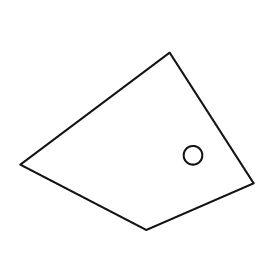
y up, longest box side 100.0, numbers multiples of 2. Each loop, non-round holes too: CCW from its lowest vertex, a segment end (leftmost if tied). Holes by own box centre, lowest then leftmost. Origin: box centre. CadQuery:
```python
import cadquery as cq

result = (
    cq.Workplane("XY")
    .moveTo(4.0, -38.0)
    .lineTo(50.0, -18.0)
    .lineTo(14.0, 38.0)
    .lineTo(-50.0, -10.0)
    .close()
    .moveTo(24.0, -6.0)
    .circle(4.0)
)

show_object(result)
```